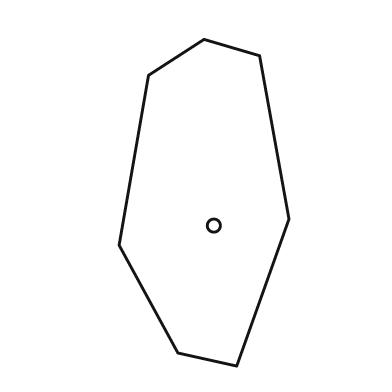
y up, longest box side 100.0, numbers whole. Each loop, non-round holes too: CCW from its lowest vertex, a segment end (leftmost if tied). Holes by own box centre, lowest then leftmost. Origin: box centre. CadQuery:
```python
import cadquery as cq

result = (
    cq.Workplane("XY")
    .moveTo(10.0, -50.0)
    .lineTo(26.0, -5.0)
    .lineTo(17.0, 45.0)
    .lineTo(0.0, 50.0)
    .lineTo(-17.0, 39.0)
    .lineTo(-26.0, -13.0)
    .lineTo(-8.0, -46.0)
    .close()
    .moveTo(3.0, -7.0)
    .circle(2.0)
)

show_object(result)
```